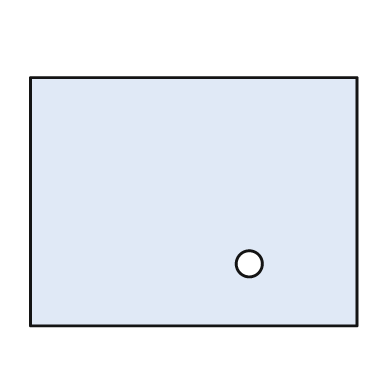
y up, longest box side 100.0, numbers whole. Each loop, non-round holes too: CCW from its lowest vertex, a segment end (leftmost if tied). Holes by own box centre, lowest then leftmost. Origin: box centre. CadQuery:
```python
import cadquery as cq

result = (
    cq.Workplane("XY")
    .moveTo(-50.0, -38.0)
    .lineTo(50.0, -38.0)
    .lineTo(50.0, 38.0)
    .lineTo(-50.0, 38.0)
    .close()
    .moveTo(17.0, -19.0)
    .circle(4.0)
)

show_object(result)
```